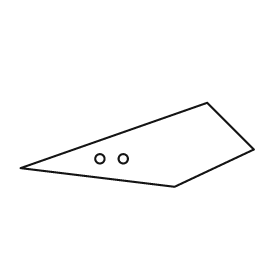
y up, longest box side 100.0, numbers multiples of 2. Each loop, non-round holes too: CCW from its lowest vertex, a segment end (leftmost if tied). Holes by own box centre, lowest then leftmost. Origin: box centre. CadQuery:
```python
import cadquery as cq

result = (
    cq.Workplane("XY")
    .moveTo(16.0, -18.0)
    .lineTo(50.0, -2.0)
    .lineTo(30.0, 18.0)
    .lineTo(-50.0, -10.0)
    .close()
    .moveTo(-16.0, -6.0)
    .circle(2.0)
    .moveTo(-6.0, -6.0)
    .circle(2.0)
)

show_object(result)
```